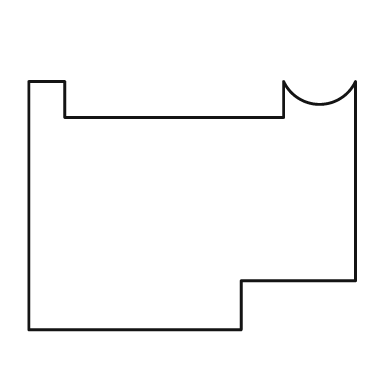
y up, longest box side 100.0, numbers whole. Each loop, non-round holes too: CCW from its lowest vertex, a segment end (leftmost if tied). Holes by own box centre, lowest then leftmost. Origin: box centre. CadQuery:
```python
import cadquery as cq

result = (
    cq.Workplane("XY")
    .moveTo(-50.0, -38.0)
    .lineTo(15.0, -38.0)
    .lineTo(15.0, -23.0)
    .lineTo(50.0, -23.0)
    .lineTo(50.0, 38.0)
    .threePointArc((39.0, 31.0), (28.0, 38.0))
    .lineTo(28.0, 27.0)
    .lineTo(-39.0, 27.0)
    .lineTo(-39.0, 38.0)
    .lineTo(-50.0, 38.0)
    .close()
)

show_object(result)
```